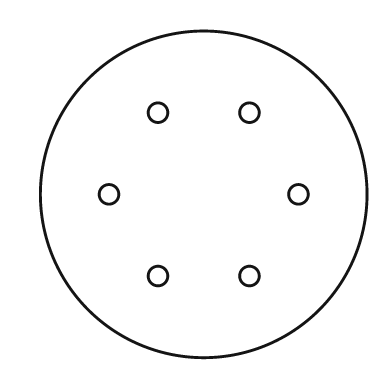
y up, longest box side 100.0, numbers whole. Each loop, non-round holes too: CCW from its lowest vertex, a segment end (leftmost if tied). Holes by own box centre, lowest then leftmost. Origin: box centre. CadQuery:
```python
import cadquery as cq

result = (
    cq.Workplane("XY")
    .moveTo(0.0, 0.0)
    .circle(50.0)
    .moveTo(-14.0, -25.0)
    .circle(3.0)
    .moveTo(14.0, -25.0)
    .circle(3.0)
    .moveTo(-29.0, 0.0)
    .circle(3.0)
    .moveTo(29.0, 0.0)
    .circle(3.0)
    .moveTo(-14.0, 25.0)
    .circle(3.0)
    .moveTo(14.0, 25.0)
    .circle(3.0)
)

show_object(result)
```